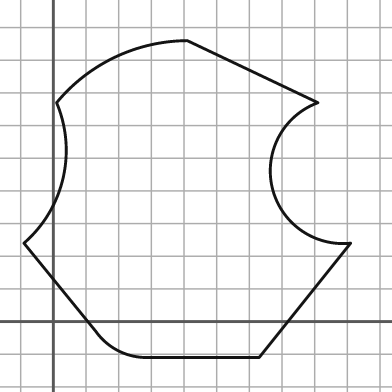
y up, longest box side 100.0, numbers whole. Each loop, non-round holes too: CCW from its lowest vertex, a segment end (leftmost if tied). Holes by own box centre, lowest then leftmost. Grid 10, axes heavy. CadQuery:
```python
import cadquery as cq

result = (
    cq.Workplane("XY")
    .moveTo(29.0, -11.0)
    .lineTo(63.0, -11.0)
    .lineTo(91.0, 24.0)
    .threePointArc((67.0, 41.0), (81.0, 67.0))
    .lineTo(41.0, 86.0)
    .threePointArc((19.0, 81.0), (1.0, 67.0))
    .threePointArc((3.0, 44.0), (-9.0, 24.0))
    .lineTo(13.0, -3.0)
    .threePointArc((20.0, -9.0), (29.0, -11.0))
    .close()
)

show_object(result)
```